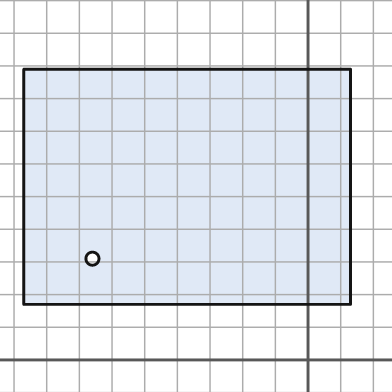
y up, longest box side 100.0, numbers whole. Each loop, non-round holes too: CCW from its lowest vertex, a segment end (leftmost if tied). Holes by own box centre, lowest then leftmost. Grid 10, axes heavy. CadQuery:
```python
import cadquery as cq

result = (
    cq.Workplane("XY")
    .moveTo(-87.0, 17.0)
    .lineTo(13.0, 17.0)
    .lineTo(13.0, 89.0)
    .lineTo(-87.0, 89.0)
    .close()
    .moveTo(-66.0, 31.0)
    .circle(2.0)
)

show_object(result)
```